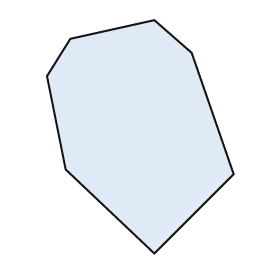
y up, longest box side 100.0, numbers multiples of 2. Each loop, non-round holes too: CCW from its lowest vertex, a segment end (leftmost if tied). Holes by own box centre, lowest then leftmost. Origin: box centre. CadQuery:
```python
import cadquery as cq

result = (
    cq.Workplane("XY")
    .moveTo(6.0, -50.0)
    .lineTo(40.0, -16.0)
    .lineTo(22.0, 36.0)
    .lineTo(6.0, 50.0)
    .lineTo(-30.0, 42.0)
    .lineTo(-40.0, 26.0)
    .lineTo(-32.0, -14.0)
    .close()
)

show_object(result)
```